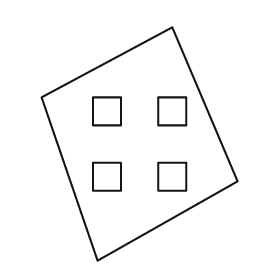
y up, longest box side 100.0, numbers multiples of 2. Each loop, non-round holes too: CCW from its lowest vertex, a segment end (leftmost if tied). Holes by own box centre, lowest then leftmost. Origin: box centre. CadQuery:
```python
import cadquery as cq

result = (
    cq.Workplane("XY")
    .moveTo(-18.0, -50.0)
    .lineTo(42.0, -16.0)
    .lineTo(14.0, 50.0)
    .lineTo(-42.0, 20.0)
    .close()
    .moveTo(-20.0, -20.0)
    .lineTo(-8.0, -20.0)
    .lineTo(-8.0, -8.0)
    .lineTo(-20.0, -8.0)
    .close()
    .moveTo(8.0, -20.0)
    .lineTo(20.0, -20.0)
    .lineTo(20.0, -8.0)
    .lineTo(8.0, -8.0)
    .close()
    .moveTo(-20.0, 8.0)
    .lineTo(-8.0, 8.0)
    .lineTo(-8.0, 20.0)
    .lineTo(-20.0, 20.0)
    .close()
    .moveTo(8.0, 8.0)
    .lineTo(20.0, 8.0)
    .lineTo(20.0, 20.0)
    .lineTo(8.0, 20.0)
    .close()
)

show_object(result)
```